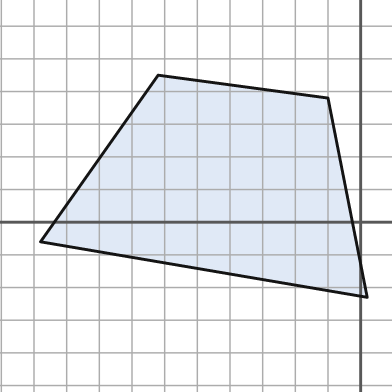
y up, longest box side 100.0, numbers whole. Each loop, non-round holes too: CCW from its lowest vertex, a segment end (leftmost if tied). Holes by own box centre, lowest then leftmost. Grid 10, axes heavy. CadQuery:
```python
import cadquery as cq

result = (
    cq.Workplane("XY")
    .moveTo(2.0, -23.0)
    .lineTo(-10.0, 38.0)
    .lineTo(-62.0, 45.0)
    .lineTo(-98.0, -6.0)
    .close()
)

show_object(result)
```